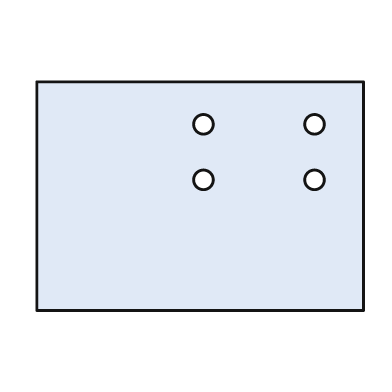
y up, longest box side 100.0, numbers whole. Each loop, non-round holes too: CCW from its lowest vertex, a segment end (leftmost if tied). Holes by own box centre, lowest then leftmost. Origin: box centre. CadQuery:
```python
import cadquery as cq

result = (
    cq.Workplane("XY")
    .moveTo(-50.0, -35.0)
    .lineTo(50.0, -35.0)
    .lineTo(50.0, 35.0)
    .lineTo(-50.0, 35.0)
    .close()
    .moveTo(1.0, 5.0)
    .circle(3.0)
    .moveTo(35.0, 5.0)
    .circle(3.0)
    .moveTo(1.0, 22.0)
    .circle(3.0)
    .moveTo(35.0, 22.0)
    .circle(3.0)
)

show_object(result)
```